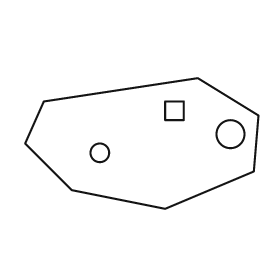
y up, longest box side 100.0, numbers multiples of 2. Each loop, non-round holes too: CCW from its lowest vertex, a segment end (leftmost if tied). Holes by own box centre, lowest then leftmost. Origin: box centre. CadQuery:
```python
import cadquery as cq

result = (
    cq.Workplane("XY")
    .moveTo(10.0, -28.0)
    .lineTo(48.0, -12.0)
    .lineTo(50.0, 12.0)
    .lineTo(24.0, 28.0)
    .lineTo(-42.0, 18.0)
    .lineTo(-50.0, 0.0)
    .lineTo(-30.0, -20.0)
    .close()
    .moveTo(-18.0, -4.0)
    .circle(4.0)
    .moveTo(38.0, 4.0)
    .circle(6.0)
    .moveTo(10.0, 10.0)
    .lineTo(18.0, 10.0)
    .lineTo(18.0, 18.0)
    .lineTo(10.0, 18.0)
    .close()
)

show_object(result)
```